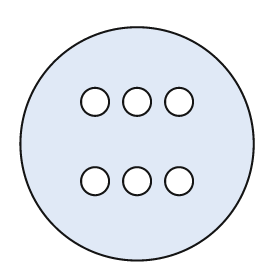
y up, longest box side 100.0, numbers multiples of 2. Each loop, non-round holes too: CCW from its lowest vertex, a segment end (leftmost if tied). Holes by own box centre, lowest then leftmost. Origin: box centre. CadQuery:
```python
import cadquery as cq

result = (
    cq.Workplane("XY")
    .moveTo(0.0, 0.0)
    .circle(50.0)
    .moveTo(-18.0, -16.0)
    .circle(6.0)
    .moveTo(0.0, -16.0)
    .circle(6.0)
    .moveTo(18.0, -16.0)
    .circle(6.0)
    .moveTo(-18.0, 18.0)
    .circle(6.0)
    .moveTo(0.0, 18.0)
    .circle(6.0)
    .moveTo(18.0, 18.0)
    .circle(6.0)
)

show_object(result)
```